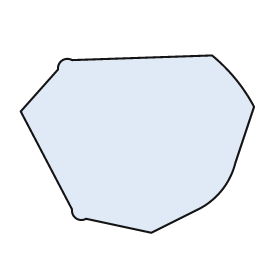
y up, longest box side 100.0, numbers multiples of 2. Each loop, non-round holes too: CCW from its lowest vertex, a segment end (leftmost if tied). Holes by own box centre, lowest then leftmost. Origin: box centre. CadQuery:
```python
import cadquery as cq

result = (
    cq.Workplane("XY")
    .moveTo(6.0, -38.0)
    .lineTo(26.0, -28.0)
    .threePointArc((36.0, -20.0), (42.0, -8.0))
    .lineTo(50.0, 16.0)
    .threePointArc((42.0, 28.0), (32.0, 38.0))
    .lineTo(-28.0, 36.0)
    .threePointArc((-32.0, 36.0), (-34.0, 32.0))
    .lineTo(-50.0, 14.0)
    .lineTo(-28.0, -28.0)
    .threePointArc((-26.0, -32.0), (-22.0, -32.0))
    .close()
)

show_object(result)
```